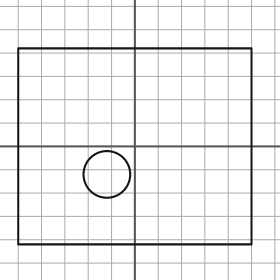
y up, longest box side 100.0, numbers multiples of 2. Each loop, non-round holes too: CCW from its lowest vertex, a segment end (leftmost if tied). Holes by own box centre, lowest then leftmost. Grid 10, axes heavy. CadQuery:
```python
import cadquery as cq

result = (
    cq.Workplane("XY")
    .moveTo(-50.0, -42.0)
    .lineTo(50.0, -42.0)
    .lineTo(50.0, 42.0)
    .lineTo(-50.0, 42.0)
    .close()
    .moveTo(-12.0, -12.0)
    .circle(10.0)
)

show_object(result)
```